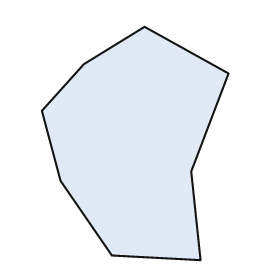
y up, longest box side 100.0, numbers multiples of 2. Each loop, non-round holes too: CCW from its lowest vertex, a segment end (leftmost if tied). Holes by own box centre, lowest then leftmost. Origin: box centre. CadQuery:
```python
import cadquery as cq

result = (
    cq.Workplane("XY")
    .moveTo(28.0, -50.0)
    .lineTo(24.0, -12.0)
    .lineTo(40.0, 30.0)
    .lineTo(4.0, 50.0)
    .lineTo(-22.0, 34.0)
    .lineTo(-40.0, 14.0)
    .lineTo(-32.0, -16.0)
    .lineTo(-10.0, -48.0)
    .close()
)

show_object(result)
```